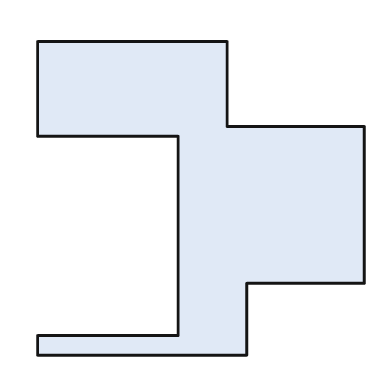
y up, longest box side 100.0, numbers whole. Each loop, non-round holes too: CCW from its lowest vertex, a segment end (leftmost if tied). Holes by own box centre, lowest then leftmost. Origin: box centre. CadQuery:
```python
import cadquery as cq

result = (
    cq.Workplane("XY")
    .moveTo(-50.0, -48.0)
    .lineTo(14.0, -48.0)
    .lineTo(14.0, -26.0)
    .lineTo(50.0, -26.0)
    .lineTo(50.0, 22.0)
    .lineTo(8.0, 22.0)
    .lineTo(8.0, 48.0)
    .lineTo(-50.0, 48.0)
    .lineTo(-50.0, 19.0)
    .lineTo(-7.0, 19.0)
    .lineTo(-7.0, -42.0)
    .lineTo(-50.0, -42.0)
    .close()
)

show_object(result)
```